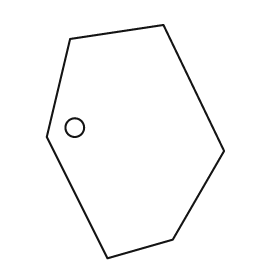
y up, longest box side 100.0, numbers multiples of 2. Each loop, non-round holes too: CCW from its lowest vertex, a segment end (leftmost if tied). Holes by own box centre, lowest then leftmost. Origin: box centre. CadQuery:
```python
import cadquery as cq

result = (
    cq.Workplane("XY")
    .moveTo(-12.0, -50.0)
    .lineTo(16.0, -42.0)
    .lineTo(38.0, -4.0)
    .lineTo(12.0, 50.0)
    .lineTo(-28.0, 44.0)
    .lineTo(-38.0, 2.0)
    .close()
    .moveTo(-26.0, 6.0)
    .circle(4.0)
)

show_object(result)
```